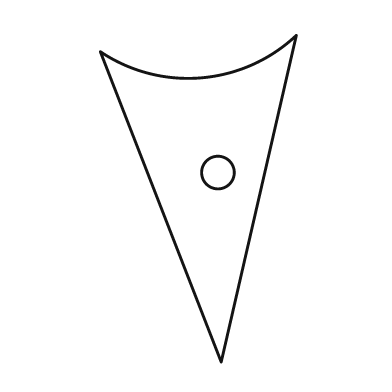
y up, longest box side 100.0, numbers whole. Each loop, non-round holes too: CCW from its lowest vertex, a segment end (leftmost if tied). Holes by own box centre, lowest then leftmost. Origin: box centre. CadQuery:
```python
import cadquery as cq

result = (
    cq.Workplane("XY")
    .moveTo(7.0, -50.0)
    .lineTo(30.0, 50.0)
    .threePointArc((1.0, 37.0), (-30.0, 45.0))
    .close()
    .moveTo(6.0, 8.0)
    .circle(5.0)
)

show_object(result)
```